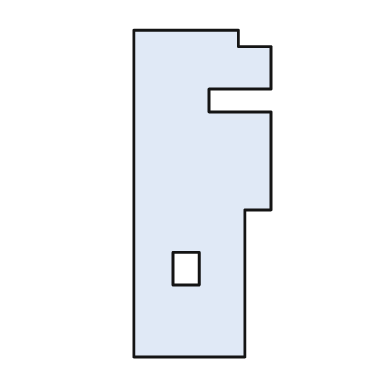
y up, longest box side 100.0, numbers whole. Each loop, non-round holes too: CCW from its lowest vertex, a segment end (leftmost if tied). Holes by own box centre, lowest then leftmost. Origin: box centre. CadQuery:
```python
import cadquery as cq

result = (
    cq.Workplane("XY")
    .moveTo(-21.0, -50.0)
    .lineTo(13.0, -50.0)
    .lineTo(13.0, -5.0)
    .lineTo(21.0, -5.0)
    .lineTo(21.0, 25.0)
    .lineTo(2.0, 25.0)
    .lineTo(2.0, 32.0)
    .lineTo(21.0, 32.0)
    .lineTo(21.0, 45.0)
    .lineTo(11.0, 45.0)
    .lineTo(11.0, 50.0)
    .lineTo(-21.0, 50.0)
    .close()
    .moveTo(-9.0, -28.0)
    .lineTo(-1.0, -28.0)
    .lineTo(-1.0, -18.0)
    .lineTo(-9.0, -18.0)
    .close()
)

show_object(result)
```